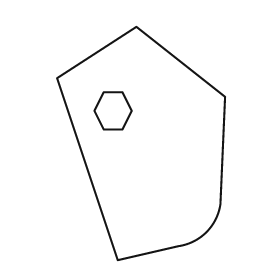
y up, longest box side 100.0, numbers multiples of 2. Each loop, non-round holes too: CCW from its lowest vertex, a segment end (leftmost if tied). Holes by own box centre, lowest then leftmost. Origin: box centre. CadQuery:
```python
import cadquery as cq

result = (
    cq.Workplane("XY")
    .moveTo(-10.0, -50.0)
    .lineTo(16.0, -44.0)
    .threePointArc((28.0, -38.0), (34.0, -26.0))
    .lineTo(36.0, 20.0)
    .lineTo(-2.0, 50.0)
    .lineTo(-36.0, 28.0)
    .close()
    .moveTo(-16.0, 6.0)
    .lineTo(-8.0, 6.0)
    .lineTo(-4.0, 14.0)
    .lineTo(-8.0, 22.0)
    .lineTo(-16.0, 22.0)
    .lineTo(-20.0, 14.0)
    .close()
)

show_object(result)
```